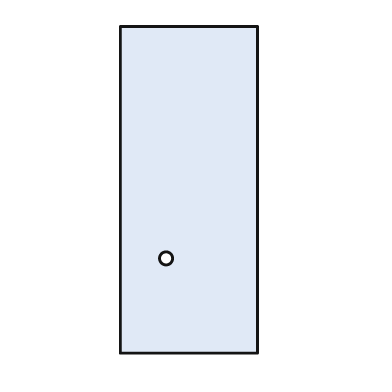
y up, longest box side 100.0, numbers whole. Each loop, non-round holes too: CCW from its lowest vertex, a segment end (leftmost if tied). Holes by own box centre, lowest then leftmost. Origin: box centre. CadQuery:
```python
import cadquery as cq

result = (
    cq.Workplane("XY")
    .moveTo(-21.0, -50.0)
    .lineTo(21.0, -50.0)
    .lineTo(21.0, 50.0)
    .lineTo(-21.0, 50.0)
    .close()
    .moveTo(-7.0, -21.0)
    .circle(2.0)
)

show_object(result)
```